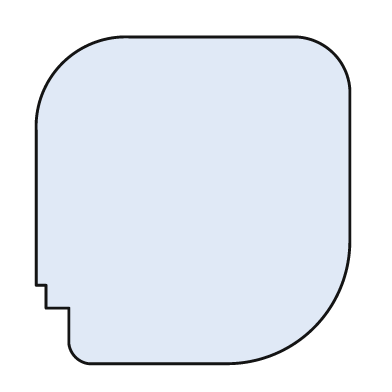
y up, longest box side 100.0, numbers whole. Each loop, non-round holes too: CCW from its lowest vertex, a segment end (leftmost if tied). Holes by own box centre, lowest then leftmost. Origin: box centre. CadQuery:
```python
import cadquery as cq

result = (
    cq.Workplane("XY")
    .moveTo(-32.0, -50.0)
    .lineTo(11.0, -50.0)
    .threePointArc((37.0, -39.0), (48.0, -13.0))
    .lineTo(48.0, 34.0)
    .threePointArc((43.0, 45.0), (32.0, 50.0))
    .lineTo(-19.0, 50.0)
    .threePointArc((-40.0, 42.0), (-48.0, 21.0))
    .lineTo(-48.0, -26.0)
    .lineTo(-45.0, -26.0)
    .lineTo(-45.0, -33.0)
    .lineTo(-38.0, -33.0)
    .lineTo(-38.0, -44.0)
    .threePointArc((-36.0, -48.0), (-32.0, -50.0))
    .close()
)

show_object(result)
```